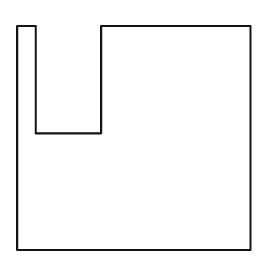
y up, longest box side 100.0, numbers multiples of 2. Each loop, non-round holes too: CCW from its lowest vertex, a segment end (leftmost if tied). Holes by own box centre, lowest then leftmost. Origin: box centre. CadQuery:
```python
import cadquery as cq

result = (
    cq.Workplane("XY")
    .moveTo(-50.0, -48.0)
    .lineTo(50.0, -48.0)
    .lineTo(50.0, 48.0)
    .lineTo(-14.0, 48.0)
    .lineTo(-14.0, 2.0)
    .lineTo(-42.0, 2.0)
    .lineTo(-42.0, 48.0)
    .lineTo(-50.0, 48.0)
    .close()
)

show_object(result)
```